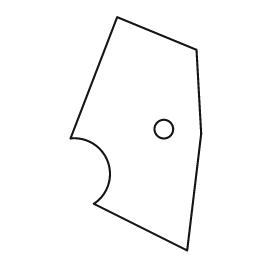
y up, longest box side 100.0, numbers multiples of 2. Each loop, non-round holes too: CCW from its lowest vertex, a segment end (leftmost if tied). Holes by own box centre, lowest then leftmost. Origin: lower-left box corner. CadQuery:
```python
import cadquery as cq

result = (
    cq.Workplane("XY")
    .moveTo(50.0, 0.0)
    .lineTo(56.0, 50.0)
    .lineTo(54.0, 86.0)
    .lineTo(20.0, 100.0)
    .lineTo(0.0, 48.0)
    .threePointArc((16.0, 38.0), (10.0, 20.0))
    .close()
    .moveTo(40.0, 52.0)
    .circle(4.0)
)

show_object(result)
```